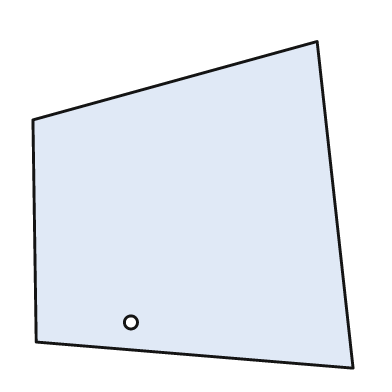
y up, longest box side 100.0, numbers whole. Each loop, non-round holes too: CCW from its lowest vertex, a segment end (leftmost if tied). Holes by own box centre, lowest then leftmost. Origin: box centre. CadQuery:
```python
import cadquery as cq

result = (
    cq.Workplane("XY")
    .moveTo(49.0, -50.0)
    .lineTo(38.0, 50.0)
    .lineTo(-49.0, 26.0)
    .lineTo(-48.0, -42.0)
    .close()
    .moveTo(-19.0, -36.0)
    .circle(2.0)
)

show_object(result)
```